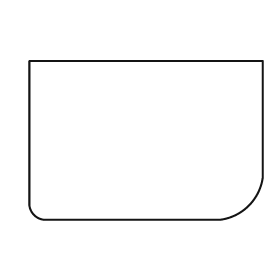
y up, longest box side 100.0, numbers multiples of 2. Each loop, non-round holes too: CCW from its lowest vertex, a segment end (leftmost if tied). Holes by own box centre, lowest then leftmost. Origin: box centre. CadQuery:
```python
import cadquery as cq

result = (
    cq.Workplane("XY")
    .moveTo(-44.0, -34.0)
    .lineTo(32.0, -34.0)
    .threePointArc((44.0, -28.0), (50.0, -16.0))
    .lineTo(50.0, 34.0)
    .lineTo(-50.0, 34.0)
    .lineTo(-50.0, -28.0)
    .threePointArc((-48.0, -32.0), (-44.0, -34.0))
    .close()
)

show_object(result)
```